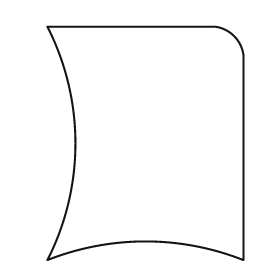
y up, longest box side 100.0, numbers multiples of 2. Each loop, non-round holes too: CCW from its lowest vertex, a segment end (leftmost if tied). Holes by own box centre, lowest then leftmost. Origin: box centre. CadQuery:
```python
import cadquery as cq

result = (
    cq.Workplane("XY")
    .moveTo(-42.0, -50.0)
    .threePointArc((0.0, -42.0), (42.0, -50.0))
    .lineTo(42.0, 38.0)
    .threePointArc((38.0, 46.0), (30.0, 50.0))
    .lineTo(-42.0, 50.0)
    .threePointArc((-30.0, 0.0), (-42.0, -50.0))
    .close()
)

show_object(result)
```